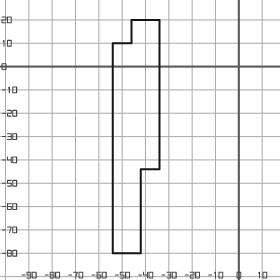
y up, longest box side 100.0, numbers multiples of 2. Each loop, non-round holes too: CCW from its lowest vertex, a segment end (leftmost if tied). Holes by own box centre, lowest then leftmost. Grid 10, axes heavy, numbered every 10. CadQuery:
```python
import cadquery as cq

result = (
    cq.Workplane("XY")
    .moveTo(-54.0, -80.0)
    .lineTo(-42.0, -80.0)
    .lineTo(-42.0, -44.0)
    .lineTo(-34.0, -44.0)
    .lineTo(-34.0, 20.0)
    .lineTo(-46.0, 20.0)
    .lineTo(-46.0, 10.0)
    .lineTo(-54.0, 10.0)
    .close()
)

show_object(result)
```